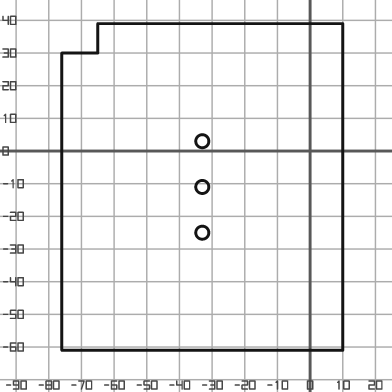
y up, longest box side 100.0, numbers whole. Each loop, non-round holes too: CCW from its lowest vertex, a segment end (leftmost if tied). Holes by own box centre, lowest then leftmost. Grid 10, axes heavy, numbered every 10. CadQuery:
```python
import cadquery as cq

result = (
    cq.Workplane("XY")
    .moveTo(-76.0, -61.0)
    .lineTo(10.0, -61.0)
    .lineTo(10.0, 39.0)
    .lineTo(-65.0, 39.0)
    .lineTo(-65.0, 30.0)
    .lineTo(-76.0, 30.0)
    .close()
    .moveTo(-33.0, -25.0)
    .circle(2.0)
    .moveTo(-33.0, -11.0)
    .circle(2.0)
    .moveTo(-33.0, 3.0)
    .circle(2.0)
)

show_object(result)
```